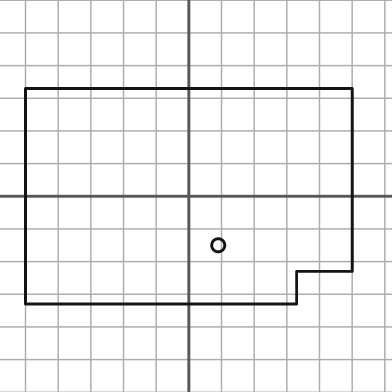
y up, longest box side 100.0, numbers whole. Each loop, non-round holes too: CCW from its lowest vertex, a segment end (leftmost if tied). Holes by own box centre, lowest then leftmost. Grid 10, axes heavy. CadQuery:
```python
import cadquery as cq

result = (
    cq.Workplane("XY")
    .moveTo(-50.0, -33.0)
    .lineTo(33.0, -33.0)
    .lineTo(33.0, -23.0)
    .lineTo(50.0, -23.0)
    .lineTo(50.0, 33.0)
    .lineTo(-50.0, 33.0)
    .close()
    .moveTo(9.0, -15.0)
    .circle(2.0)
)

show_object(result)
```